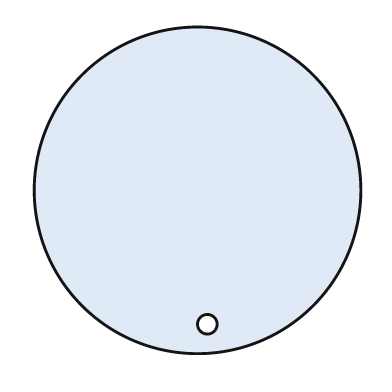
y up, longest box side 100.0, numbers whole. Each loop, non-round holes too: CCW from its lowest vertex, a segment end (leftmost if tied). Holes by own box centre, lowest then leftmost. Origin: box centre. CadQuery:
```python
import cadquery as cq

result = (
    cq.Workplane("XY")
    .moveTo(0.0, 0.0)
    .circle(50.0)
    .moveTo(3.0, -41.0)
    .circle(3.0)
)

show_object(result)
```